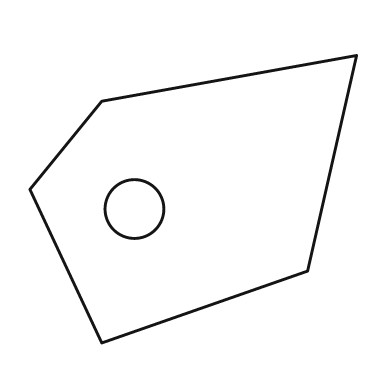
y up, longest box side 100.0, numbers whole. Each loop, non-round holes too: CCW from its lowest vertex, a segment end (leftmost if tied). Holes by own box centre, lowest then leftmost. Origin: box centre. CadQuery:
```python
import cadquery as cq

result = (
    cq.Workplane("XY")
    .moveTo(-28.0, -44.0)
    .lineTo(35.0, -22.0)
    .lineTo(50.0, 44.0)
    .lineTo(-28.0, 30.0)
    .lineTo(-50.0, 3.0)
    .close()
    .moveTo(-18.0, -3.0)
    .circle(9.0)
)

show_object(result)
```